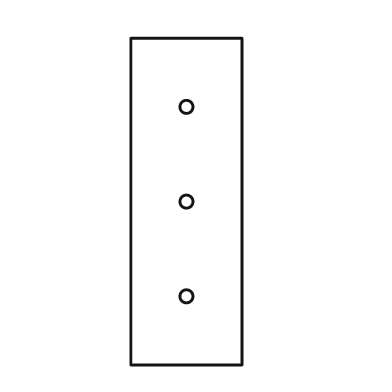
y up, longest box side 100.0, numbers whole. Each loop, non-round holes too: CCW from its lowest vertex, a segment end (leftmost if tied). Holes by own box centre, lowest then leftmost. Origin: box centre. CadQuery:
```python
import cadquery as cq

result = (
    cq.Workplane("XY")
    .moveTo(-17.0, -50.0)
    .lineTo(17.0, -50.0)
    .lineTo(17.0, 50.0)
    .lineTo(-17.0, 50.0)
    .close()
    .moveTo(0.0, -29.0)
    .circle(2.0)
    .moveTo(0.0, 0.0)
    .circle(2.0)
    .moveTo(0.0, 29.0)
    .circle(2.0)
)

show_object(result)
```